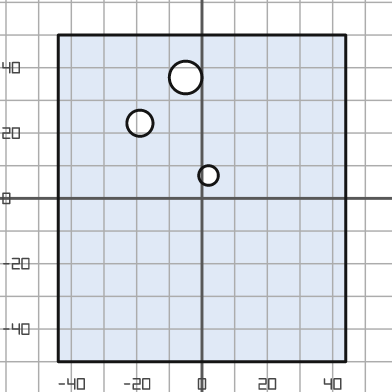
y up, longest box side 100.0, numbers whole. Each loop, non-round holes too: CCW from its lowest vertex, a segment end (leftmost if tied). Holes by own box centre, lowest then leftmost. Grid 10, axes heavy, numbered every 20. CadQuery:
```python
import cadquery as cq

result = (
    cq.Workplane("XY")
    .moveTo(-44.0, -50.0)
    .lineTo(44.0, -50.0)
    .lineTo(44.0, 50.0)
    .lineTo(-44.0, 50.0)
    .close()
    .moveTo(2.0, 7.0)
    .circle(3.0)
    .moveTo(-19.0, 23.0)
    .circle(4.0)
    .moveTo(-5.0, 37.0)
    .circle(5.0)
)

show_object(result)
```